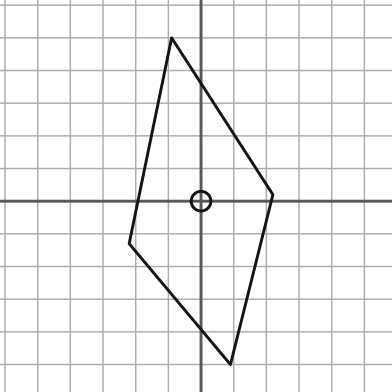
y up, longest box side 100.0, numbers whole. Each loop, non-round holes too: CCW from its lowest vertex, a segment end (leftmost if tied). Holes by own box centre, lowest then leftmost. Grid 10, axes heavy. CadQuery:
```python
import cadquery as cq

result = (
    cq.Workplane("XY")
    .moveTo(9.0, -50.0)
    .lineTo(22.0, 2.0)
    .lineTo(-9.0, 50.0)
    .lineTo(-22.0, -13.0)
    .close()
    .moveTo(0.0, 0.0)
    .circle(3.0)
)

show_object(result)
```